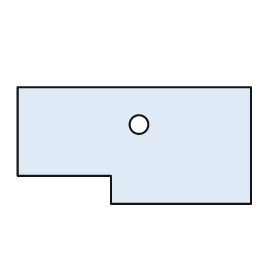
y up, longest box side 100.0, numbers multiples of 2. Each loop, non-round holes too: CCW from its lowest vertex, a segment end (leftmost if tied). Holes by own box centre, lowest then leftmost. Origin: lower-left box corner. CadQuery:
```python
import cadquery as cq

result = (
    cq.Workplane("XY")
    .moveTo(40.0, 0.0)
    .lineTo(100.0, 0.0)
    .lineTo(100.0, 50.0)
    .lineTo(0.0, 50.0)
    .lineTo(0.0, 12.0)
    .lineTo(40.0, 12.0)
    .close()
    .moveTo(52.0, 34.0)
    .circle(4.0)
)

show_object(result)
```